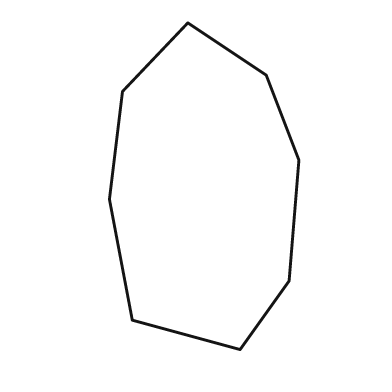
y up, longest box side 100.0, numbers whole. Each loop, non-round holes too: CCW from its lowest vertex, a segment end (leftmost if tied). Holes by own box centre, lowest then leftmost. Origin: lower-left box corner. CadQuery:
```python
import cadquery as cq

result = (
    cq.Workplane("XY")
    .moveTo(40.0, 0.0)
    .lineTo(55.0, 21.0)
    .lineTo(58.0, 58.0)
    .lineTo(48.0, 84.0)
    .lineTo(24.0, 100.0)
    .lineTo(4.0, 79.0)
    .lineTo(0.0, 46.0)
    .lineTo(7.0, 9.0)
    .close()
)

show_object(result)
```